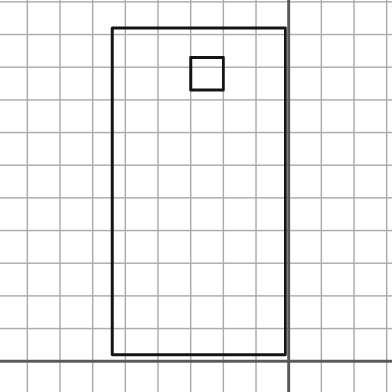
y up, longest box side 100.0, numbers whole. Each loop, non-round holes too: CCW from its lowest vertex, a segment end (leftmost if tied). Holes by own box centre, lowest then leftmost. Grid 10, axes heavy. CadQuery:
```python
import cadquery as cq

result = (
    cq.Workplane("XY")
    .moveTo(-54.0, 2.0)
    .lineTo(-1.0, 2.0)
    .lineTo(-1.0, 102.0)
    .lineTo(-54.0, 102.0)
    .close()
    .moveTo(-30.0, 83.0)
    .lineTo(-20.0, 83.0)
    .lineTo(-20.0, 93.0)
    .lineTo(-30.0, 93.0)
    .close()
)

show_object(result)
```